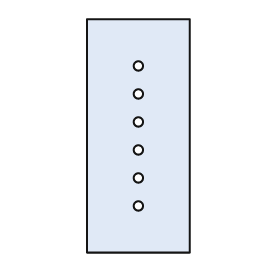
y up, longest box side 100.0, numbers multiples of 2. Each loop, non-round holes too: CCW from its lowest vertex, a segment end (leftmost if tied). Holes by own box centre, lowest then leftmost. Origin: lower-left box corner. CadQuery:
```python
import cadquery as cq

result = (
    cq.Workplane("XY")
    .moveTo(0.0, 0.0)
    .lineTo(44.0, 0.0)
    .lineTo(44.0, 100.0)
    .lineTo(0.0, 100.0)
    .close()
    .moveTo(22.0, 20.0)
    .circle(2.0)
    .moveTo(22.0, 32.0)
    .circle(2.0)
    .moveTo(22.0, 44.0)
    .circle(2.0)
    .moveTo(22.0, 56.0)
    .circle(2.0)
    .moveTo(22.0, 68.0)
    .circle(2.0)
    .moveTo(22.0, 80.0)
    .circle(2.0)
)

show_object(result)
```